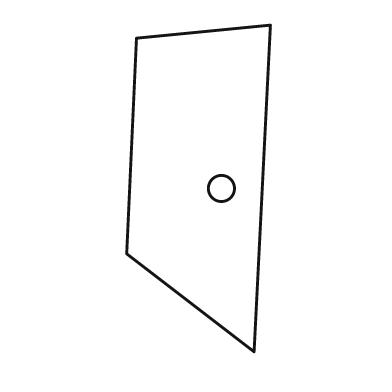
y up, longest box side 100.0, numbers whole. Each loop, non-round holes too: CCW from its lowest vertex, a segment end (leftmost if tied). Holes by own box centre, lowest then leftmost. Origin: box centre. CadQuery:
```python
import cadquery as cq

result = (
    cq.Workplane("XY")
    .moveTo(17.0, -50.0)
    .lineTo(22.0, 50.0)
    .lineTo(-19.0, 46.0)
    .lineTo(-22.0, -20.0)
    .close()
    .moveTo(7.0, 0.0)
    .circle(4.0)
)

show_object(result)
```